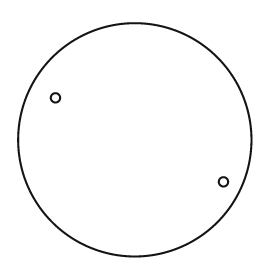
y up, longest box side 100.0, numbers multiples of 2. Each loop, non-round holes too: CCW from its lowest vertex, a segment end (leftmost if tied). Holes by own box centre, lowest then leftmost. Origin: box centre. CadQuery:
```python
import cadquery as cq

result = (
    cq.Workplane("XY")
    .moveTo(0.0, 0.0)
    .circle(50.0)
    .moveTo(38.0, -18.0)
    .circle(2.0)
    .moveTo(-34.0, 18.0)
    .circle(2.0)
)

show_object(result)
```